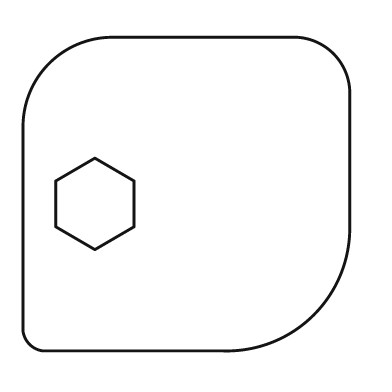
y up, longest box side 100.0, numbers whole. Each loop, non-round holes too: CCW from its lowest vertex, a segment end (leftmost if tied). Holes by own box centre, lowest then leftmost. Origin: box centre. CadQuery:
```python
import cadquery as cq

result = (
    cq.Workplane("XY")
    .moveTo(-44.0, -48.0)
    .lineTo(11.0, -48.0)
    .threePointArc((39.0, -37.0), (50.0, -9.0))
    .lineTo(50.0, 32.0)
    .threePointArc((45.0, 43.0), (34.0, 48.0))
    .lineTo(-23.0, 48.0)
    .threePointArc((-42.0, 40.0), (-50.0, 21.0))
    .lineTo(-50.0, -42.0)
    .threePointArc((-48.0, -46.0), (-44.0, -48.0))
    .close()
    .moveTo(-28.0, -17.0)
    .lineTo(-16.0, -10.0)
    .lineTo(-16.0, 4.0)
    .lineTo(-28.0, 11.0)
    .lineTo(-40.0, 4.0)
    .lineTo(-40.0, -10.0)
    .close()
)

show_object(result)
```